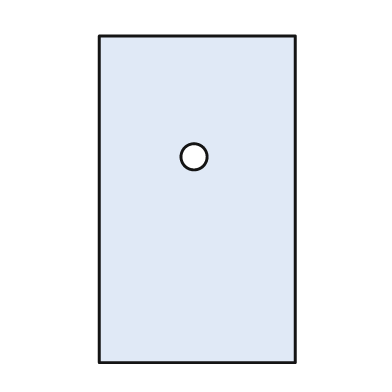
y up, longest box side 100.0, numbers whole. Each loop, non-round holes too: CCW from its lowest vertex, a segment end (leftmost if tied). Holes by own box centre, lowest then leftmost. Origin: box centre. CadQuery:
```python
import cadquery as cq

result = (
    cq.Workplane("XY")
    .moveTo(-30.0, -50.0)
    .lineTo(30.0, -50.0)
    .lineTo(30.0, 50.0)
    .lineTo(-30.0, 50.0)
    .close()
    .moveTo(-1.0, 13.0)
    .circle(4.0)
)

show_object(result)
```